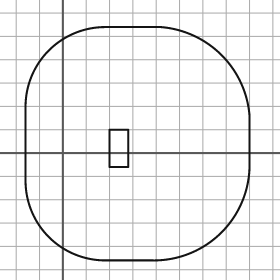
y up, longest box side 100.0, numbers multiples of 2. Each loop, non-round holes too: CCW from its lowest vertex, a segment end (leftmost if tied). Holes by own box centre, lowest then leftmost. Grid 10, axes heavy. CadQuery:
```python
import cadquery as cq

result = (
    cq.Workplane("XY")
    .moveTo(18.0, -46.0)
    .lineTo(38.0, -46.0)
    .threePointArc((68.0, -34.0), (80.0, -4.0))
    .lineTo(80.0, 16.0)
    .threePointArc((68.0, 42.0), (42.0, 54.0))
    .lineTo(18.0, 54.0)
    .threePointArc((-6.0, 44.0), (-16.0, 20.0))
    .lineTo(-16.0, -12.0)
    .threePointArc((-6.0, -36.0), (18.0, -46.0))
    .close()
    .moveTo(20.0, -6.0)
    .lineTo(28.0, -6.0)
    .lineTo(28.0, 10.0)
    .lineTo(20.0, 10.0)
    .close()
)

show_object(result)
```